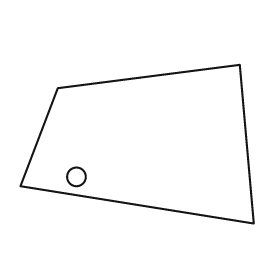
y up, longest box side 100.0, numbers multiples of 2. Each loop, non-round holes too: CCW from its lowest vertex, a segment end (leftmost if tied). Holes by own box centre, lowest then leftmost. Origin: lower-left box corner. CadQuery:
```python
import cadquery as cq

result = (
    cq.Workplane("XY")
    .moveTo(100.0, 0.0)
    .lineTo(94.0, 68.0)
    .lineTo(16.0, 58.0)
    .lineTo(0.0, 16.0)
    .close()
    .moveTo(24.0, 20.0)
    .circle(4.0)
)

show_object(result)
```